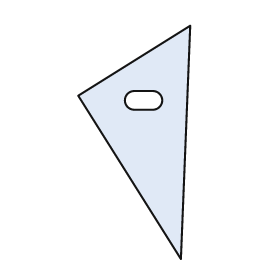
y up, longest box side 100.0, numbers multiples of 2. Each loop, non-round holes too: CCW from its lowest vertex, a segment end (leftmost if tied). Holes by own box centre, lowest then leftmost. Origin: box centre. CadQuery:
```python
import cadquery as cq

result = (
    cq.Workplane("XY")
    .moveTo(20.0, -50.0)
    .lineTo(24.0, 50.0)
    .lineTo(-24.0, 20.0)
    .close()
    .moveTo(0.0, 14.0)
    .lineTo(8.0, 14.0)
    .threePointArc((12.0, 18.0), (8.0, 22.0))
    .lineTo(0.0, 22.0)
    .threePointArc((-4.0, 18.0), (0.0, 14.0))
    .close()
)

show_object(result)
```